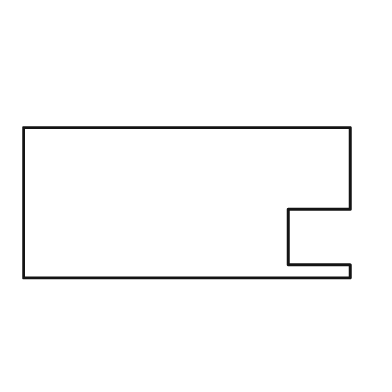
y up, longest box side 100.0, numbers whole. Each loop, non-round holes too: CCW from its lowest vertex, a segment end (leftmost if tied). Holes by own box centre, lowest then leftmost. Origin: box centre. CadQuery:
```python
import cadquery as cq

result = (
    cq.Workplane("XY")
    .moveTo(-50.0, -23.0)
    .lineTo(50.0, -23.0)
    .lineTo(50.0, -19.0)
    .lineTo(31.0, -19.0)
    .lineTo(31.0, -2.0)
    .lineTo(50.0, -2.0)
    .lineTo(50.0, 23.0)
    .lineTo(-50.0, 23.0)
    .close()
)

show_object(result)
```